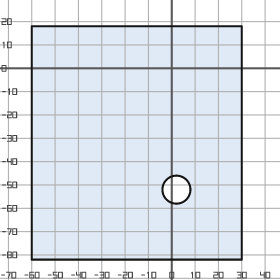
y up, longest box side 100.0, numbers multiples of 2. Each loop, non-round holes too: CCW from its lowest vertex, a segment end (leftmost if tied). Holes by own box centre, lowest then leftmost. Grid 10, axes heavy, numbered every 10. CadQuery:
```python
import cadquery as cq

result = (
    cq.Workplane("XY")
    .moveTo(-60.0, -82.0)
    .lineTo(30.0, -82.0)
    .lineTo(30.0, 18.0)
    .lineTo(-60.0, 18.0)
    .close()
    .moveTo(2.0, -52.0)
    .circle(6.0)
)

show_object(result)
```